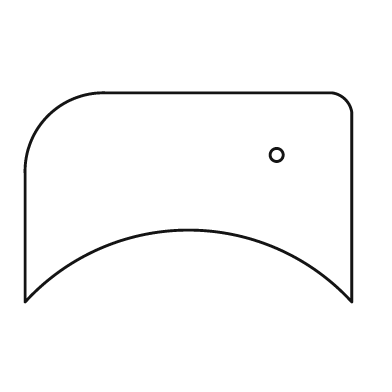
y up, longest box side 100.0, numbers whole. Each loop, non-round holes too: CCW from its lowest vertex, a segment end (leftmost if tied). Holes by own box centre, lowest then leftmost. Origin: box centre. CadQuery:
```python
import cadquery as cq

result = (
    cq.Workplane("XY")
    .moveTo(-50.0, -32.0)
    .threePointArc((0.0, -10.0), (50.0, -32.0))
    .lineTo(50.0, 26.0)
    .threePointArc((48.0, 30.0), (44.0, 32.0))
    .lineTo(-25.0, 32.0)
    .threePointArc((-43.0, 25.0), (-50.0, 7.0))
    .close()
    .moveTo(27.0, 13.0)
    .circle(2.0)
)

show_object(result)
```